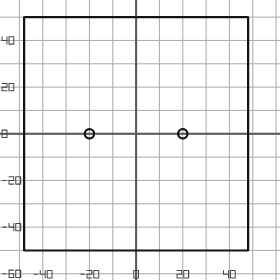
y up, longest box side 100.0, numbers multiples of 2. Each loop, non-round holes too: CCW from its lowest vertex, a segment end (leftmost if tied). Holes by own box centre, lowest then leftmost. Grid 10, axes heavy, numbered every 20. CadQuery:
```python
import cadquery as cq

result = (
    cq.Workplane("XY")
    .moveTo(-48.0, -50.0)
    .lineTo(48.0, -50.0)
    .lineTo(48.0, 50.0)
    .lineTo(-48.0, 50.0)
    .close()
    .moveTo(-20.0, 0.0)
    .circle(2.0)
    .moveTo(20.0, 0.0)
    .circle(2.0)
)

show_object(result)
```